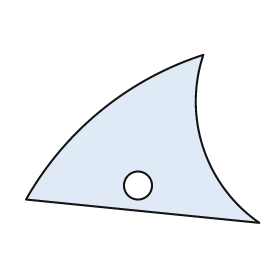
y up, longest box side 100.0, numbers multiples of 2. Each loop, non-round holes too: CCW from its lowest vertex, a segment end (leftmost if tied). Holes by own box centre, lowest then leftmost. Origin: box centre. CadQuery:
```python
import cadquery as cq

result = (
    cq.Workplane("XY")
    .moveTo(50.0, -36.0)
    .threePointArc((26.0, -4.0), (26.0, 36.0))
    .threePointArc((-18.0, 12.0), (-50.0, -26.0))
    .close()
    .moveTo(-2.0, -20.0)
    .circle(6.0)
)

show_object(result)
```